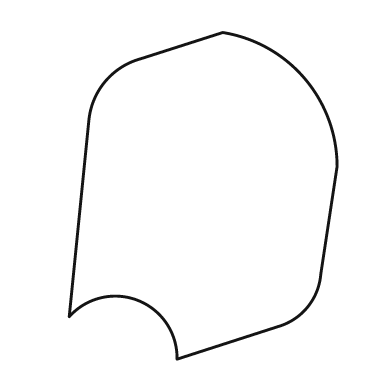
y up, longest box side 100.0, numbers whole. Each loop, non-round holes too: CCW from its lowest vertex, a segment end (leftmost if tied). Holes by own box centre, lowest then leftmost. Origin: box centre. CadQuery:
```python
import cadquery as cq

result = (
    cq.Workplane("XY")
    .moveTo(-8.0, -50.0)
    .lineTo(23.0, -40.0)
    .threePointArc((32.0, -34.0), (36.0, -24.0))
    .lineTo(41.0, 9.0)
    .threePointArc((31.0, 36.0), (6.0, 50.0))
    .lineTo(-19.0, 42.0)
    .threePointArc((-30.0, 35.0), (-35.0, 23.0))
    .lineTo(-41.0, -37.0)
    .threePointArc((-20.0, -32.0), (-8.0, -50.0))
    .close()
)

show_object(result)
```